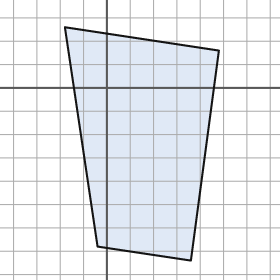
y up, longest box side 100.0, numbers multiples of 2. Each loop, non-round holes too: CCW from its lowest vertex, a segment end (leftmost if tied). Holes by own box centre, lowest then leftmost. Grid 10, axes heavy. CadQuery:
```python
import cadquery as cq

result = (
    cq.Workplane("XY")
    .moveTo(36.0, -74.0)
    .lineTo(48.0, 16.0)
    .lineTo(-18.0, 26.0)
    .lineTo(-4.0, -68.0)
    .close()
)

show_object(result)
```